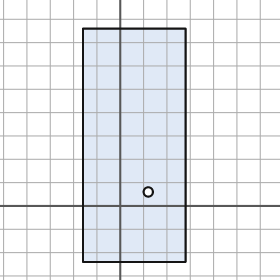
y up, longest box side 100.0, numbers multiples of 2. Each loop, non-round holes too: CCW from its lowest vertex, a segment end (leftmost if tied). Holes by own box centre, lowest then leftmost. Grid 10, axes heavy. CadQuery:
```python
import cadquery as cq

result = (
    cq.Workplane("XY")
    .moveTo(-16.0, -24.0)
    .lineTo(28.0, -24.0)
    .lineTo(28.0, 76.0)
    .lineTo(-16.0, 76.0)
    .close()
    .moveTo(12.0, 6.0)
    .circle(2.0)
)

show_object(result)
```